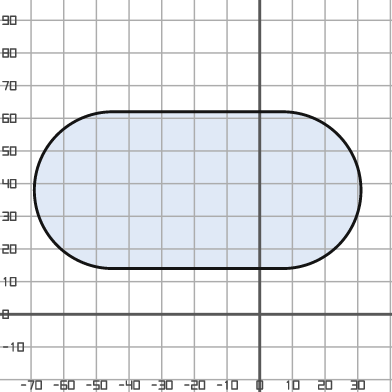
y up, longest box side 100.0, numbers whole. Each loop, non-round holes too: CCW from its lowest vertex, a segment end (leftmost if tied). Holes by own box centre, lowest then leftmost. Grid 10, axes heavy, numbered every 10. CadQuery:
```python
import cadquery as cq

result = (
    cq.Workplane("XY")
    .moveTo(-45.0, 14.0)
    .lineTo(7.0, 14.0)
    .threePointArc((31.0, 38.0), (7.0, 62.0))
    .lineTo(-45.0, 62.0)
    .threePointArc((-69.0, 38.0), (-45.0, 14.0))
    .close()
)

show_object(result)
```